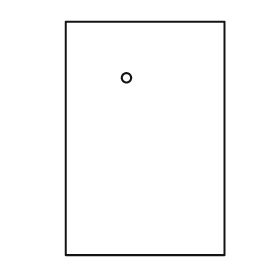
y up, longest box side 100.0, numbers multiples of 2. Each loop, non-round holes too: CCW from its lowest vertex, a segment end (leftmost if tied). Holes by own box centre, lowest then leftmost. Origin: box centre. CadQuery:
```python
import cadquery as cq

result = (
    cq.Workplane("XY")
    .moveTo(-34.0, -50.0)
    .lineTo(34.0, -50.0)
    .lineTo(34.0, 50.0)
    .lineTo(-34.0, 50.0)
    .close()
    .moveTo(-8.0, 26.0)
    .circle(2.0)
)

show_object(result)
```